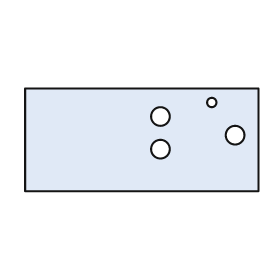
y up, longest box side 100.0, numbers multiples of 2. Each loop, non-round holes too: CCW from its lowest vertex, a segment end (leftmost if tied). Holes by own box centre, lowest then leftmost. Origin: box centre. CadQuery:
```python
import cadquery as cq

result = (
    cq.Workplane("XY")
    .moveTo(-50.0, -22.0)
    .lineTo(50.0, -22.0)
    .lineTo(50.0, 22.0)
    .lineTo(-50.0, 22.0)
    .close()
    .moveTo(8.0, -4.0)
    .circle(4.0)
    .moveTo(40.0, 2.0)
    .circle(4.0)
    .moveTo(8.0, 10.0)
    .circle(4.0)
    .moveTo(30.0, 16.0)
    .circle(2.0)
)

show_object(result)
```